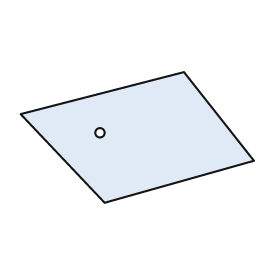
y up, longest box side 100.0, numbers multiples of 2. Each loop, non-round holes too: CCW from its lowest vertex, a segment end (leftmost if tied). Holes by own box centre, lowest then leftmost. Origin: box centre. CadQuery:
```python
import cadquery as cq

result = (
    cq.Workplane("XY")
    .moveTo(-14.0, -28.0)
    .lineTo(50.0, -10.0)
    .lineTo(20.0, 28.0)
    .lineTo(-50.0, 10.0)
    .close()
    .moveTo(-16.0, 2.0)
    .circle(2.0)
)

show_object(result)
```